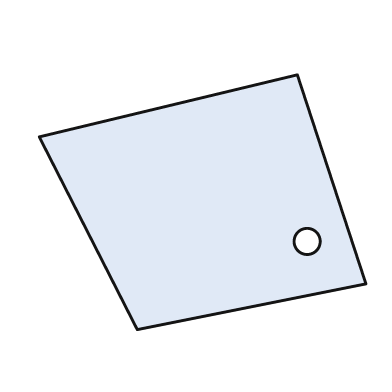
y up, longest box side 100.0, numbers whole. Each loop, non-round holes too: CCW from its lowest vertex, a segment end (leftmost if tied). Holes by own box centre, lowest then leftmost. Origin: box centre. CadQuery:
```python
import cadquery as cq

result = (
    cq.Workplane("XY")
    .moveTo(-20.0, -39.0)
    .lineTo(50.0, -25.0)
    .lineTo(29.0, 39.0)
    .lineTo(-50.0, 20.0)
    .close()
    .moveTo(32.0, -12.0)
    .circle(4.0)
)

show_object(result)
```